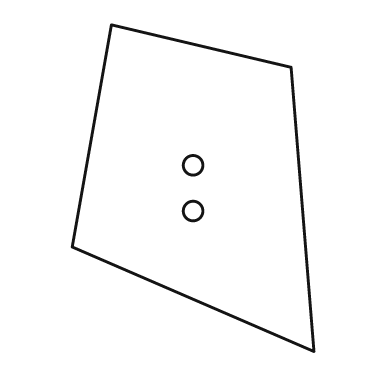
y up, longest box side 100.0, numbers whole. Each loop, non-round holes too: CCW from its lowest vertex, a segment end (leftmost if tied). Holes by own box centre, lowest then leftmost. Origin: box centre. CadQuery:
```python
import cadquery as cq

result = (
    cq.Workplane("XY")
    .moveTo(37.0, -50.0)
    .lineTo(30.0, 37.0)
    .lineTo(-25.0, 50.0)
    .lineTo(-37.0, -18.0)
    .close()
    .moveTo(0.0, -7.0)
    .circle(3.0)
    .moveTo(0.0, 7.0)
    .circle(3.0)
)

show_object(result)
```